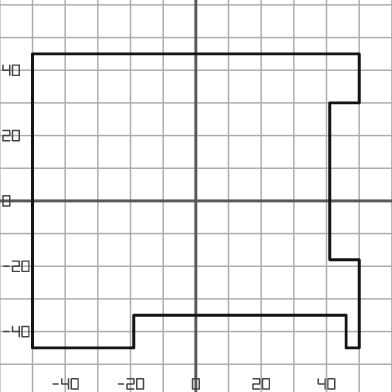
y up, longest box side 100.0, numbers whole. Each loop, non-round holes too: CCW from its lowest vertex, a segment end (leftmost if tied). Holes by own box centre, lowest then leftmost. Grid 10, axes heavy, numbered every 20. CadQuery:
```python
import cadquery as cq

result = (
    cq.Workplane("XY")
    .moveTo(-50.0, -45.0)
    .lineTo(-19.0, -45.0)
    .lineTo(-19.0, -35.0)
    .lineTo(46.0, -35.0)
    .lineTo(46.0, -45.0)
    .lineTo(50.0, -45.0)
    .lineTo(50.0, -18.0)
    .lineTo(41.0, -18.0)
    .lineTo(41.0, 30.0)
    .lineTo(50.0, 30.0)
    .lineTo(50.0, 45.0)
    .lineTo(-50.0, 45.0)
    .close()
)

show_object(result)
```